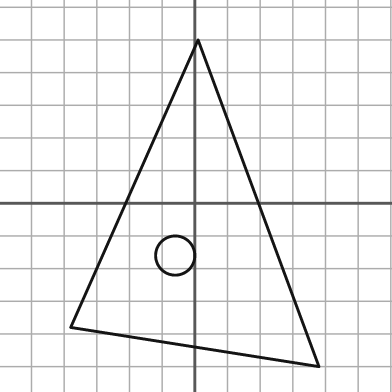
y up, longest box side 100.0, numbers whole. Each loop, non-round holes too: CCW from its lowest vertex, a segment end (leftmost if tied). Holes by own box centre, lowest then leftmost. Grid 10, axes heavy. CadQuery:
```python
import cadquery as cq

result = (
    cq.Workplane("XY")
    .moveTo(38.0, -50.0)
    .lineTo(1.0, 50.0)
    .lineTo(-38.0, -38.0)
    .close()
    .moveTo(-6.0, -16.0)
    .circle(6.0)
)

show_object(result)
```